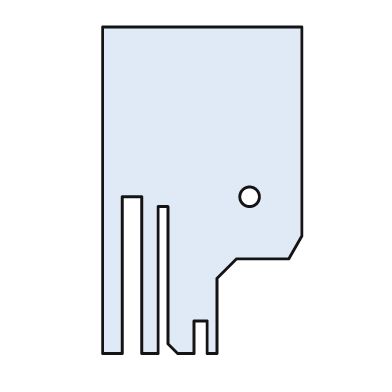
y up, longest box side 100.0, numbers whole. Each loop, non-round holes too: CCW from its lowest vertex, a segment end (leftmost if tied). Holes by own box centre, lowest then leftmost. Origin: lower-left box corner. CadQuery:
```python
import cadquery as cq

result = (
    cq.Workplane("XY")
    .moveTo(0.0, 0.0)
    .lineTo(6.0, 0.0)
    .lineTo(6.0, 48.0)
    .lineTo(12.0, 48.0)
    .lineTo(12.0, 0.0)
    .lineTo(17.0, 0.0)
    .lineTo(17.0, 45.0)
    .lineTo(20.0, 45.0)
    .lineTo(20.0, 3.0)
    .lineTo(23.0, 0.0)
    .lineTo(28.0, 0.0)
    .lineTo(28.0, 10.0)
    .lineTo(32.0, 10.0)
    .lineTo(32.0, 0.0)
    .lineTo(35.0, 0.0)
    .lineTo(35.0, 23.0)
    .lineTo(41.0, 29.0)
    .lineTo(57.0, 29.0)
    .lineTo(61.0, 36.0)
    .lineTo(61.0, 100.0)
    .lineTo(0.0, 100.0)
    .close()
    .moveTo(45.0, 48.0)
    .circle(3.0)
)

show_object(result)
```